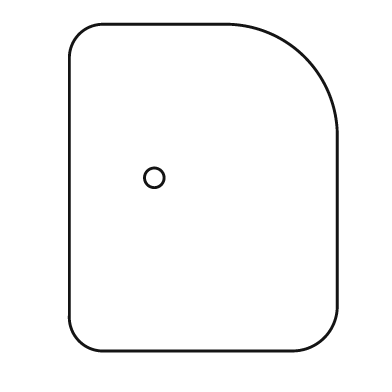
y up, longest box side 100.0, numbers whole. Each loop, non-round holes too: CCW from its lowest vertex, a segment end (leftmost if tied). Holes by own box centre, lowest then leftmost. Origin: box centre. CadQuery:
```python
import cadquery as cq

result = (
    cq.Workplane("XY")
    .moveTo(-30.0, -50.0)
    .lineTo(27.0, -50.0)
    .threePointArc((37.0, -46.0), (41.0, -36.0))
    .lineTo(41.0, 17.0)
    .threePointArc((31.0, 40.0), (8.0, 50.0))
    .lineTo(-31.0, 50.0)
    .threePointArc((-38.0, 47.0), (-41.0, 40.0))
    .lineTo(-41.0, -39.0)
    .threePointArc((-38.0, -47.0), (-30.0, -50.0))
    .close()
    .moveTo(-15.0, 3.0)
    .circle(3.0)
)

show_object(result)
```